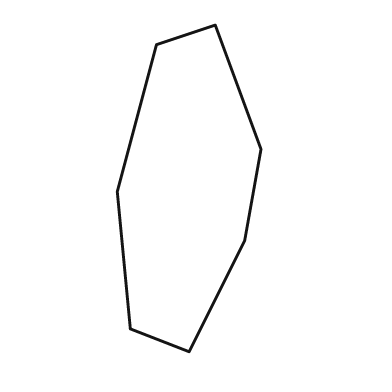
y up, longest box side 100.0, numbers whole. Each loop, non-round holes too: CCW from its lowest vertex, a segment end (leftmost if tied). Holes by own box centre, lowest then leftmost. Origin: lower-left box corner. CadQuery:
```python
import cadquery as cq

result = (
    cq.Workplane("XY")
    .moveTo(22.0, 0.0)
    .lineTo(39.0, 34.0)
    .lineTo(44.0, 62.0)
    .lineTo(30.0, 100.0)
    .lineTo(12.0, 94.0)
    .lineTo(0.0, 49.0)
    .lineTo(4.0, 7.0)
    .close()
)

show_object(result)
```